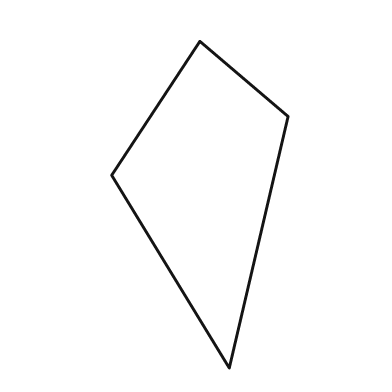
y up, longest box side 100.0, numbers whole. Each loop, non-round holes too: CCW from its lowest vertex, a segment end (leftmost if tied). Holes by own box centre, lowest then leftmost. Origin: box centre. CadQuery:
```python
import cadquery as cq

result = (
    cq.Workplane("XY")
    .moveTo(9.0, -50.0)
    .lineTo(27.0, 27.0)
    .lineTo(0.0, 50.0)
    .lineTo(-27.0, 9.0)
    .close()
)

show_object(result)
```